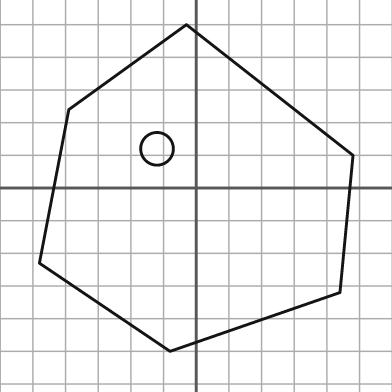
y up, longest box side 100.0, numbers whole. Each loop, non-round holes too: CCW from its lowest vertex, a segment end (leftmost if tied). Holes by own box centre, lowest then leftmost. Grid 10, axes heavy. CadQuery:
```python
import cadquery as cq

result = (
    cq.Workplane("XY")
    .moveTo(-8.0, -50.0)
    .lineTo(44.0, -32.0)
    .lineTo(48.0, 10.0)
    .lineTo(-3.0, 50.0)
    .lineTo(-39.0, 24.0)
    .lineTo(-48.0, -23.0)
    .close()
    .moveTo(-12.0, 12.0)
    .circle(5.0)
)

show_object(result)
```